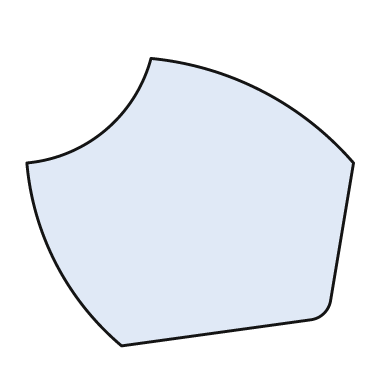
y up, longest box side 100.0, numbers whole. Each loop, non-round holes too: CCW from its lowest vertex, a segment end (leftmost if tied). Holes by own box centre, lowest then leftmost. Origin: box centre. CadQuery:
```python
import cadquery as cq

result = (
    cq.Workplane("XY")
    .moveTo(-21.0, -44.0)
    .lineTo(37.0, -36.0)
    .threePointArc((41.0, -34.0), (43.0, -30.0))
    .lineTo(50.0, 12.0)
    .threePointArc((22.0, 34.0), (-12.0, 44.0))
    .threePointArc((-26.0, 22.0), (-50.0, 12.0))
    .threePointArc((-41.0, -19.0), (-21.0, -44.0))
    .close()
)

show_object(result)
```